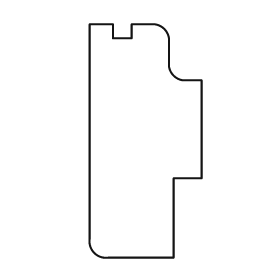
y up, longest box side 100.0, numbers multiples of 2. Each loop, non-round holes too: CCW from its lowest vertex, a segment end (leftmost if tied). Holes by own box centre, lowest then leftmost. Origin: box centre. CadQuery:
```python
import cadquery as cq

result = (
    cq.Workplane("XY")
    .moveTo(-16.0, -50.0)
    .lineTo(12.0, -50.0)
    .lineTo(12.0, -16.0)
    .lineTo(24.0, -16.0)
    .lineTo(24.0, 26.0)
    .lineTo(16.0, 26.0)
    .threePointArc((12.0, 28.0), (10.0, 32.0))
    .lineTo(10.0, 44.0)
    .threePointArc((8.0, 48.0), (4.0, 50.0))
    .lineTo(-6.0, 50.0)
    .lineTo(-6.0, 44.0)
    .lineTo(-14.0, 44.0)
    .lineTo(-14.0, 50.0)
    .lineTo(-24.0, 50.0)
    .lineTo(-24.0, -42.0)
    .threePointArc((-22.0, -48.0), (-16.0, -50.0))
    .close()
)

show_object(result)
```